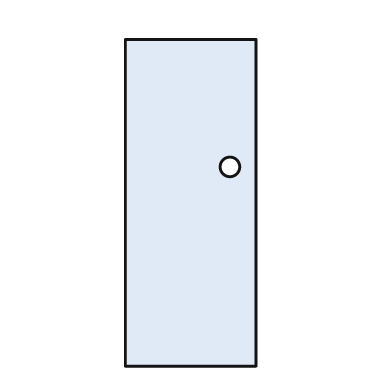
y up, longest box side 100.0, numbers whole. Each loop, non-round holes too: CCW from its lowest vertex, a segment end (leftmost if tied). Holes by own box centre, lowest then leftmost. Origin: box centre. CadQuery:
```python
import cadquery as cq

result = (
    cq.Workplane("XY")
    .moveTo(-20.0, -50.0)
    .lineTo(20.0, -50.0)
    .lineTo(20.0, 50.0)
    .lineTo(-20.0, 50.0)
    .close()
    .moveTo(12.0, 11.0)
    .circle(3.0)
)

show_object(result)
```